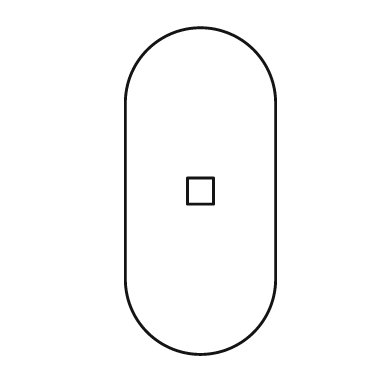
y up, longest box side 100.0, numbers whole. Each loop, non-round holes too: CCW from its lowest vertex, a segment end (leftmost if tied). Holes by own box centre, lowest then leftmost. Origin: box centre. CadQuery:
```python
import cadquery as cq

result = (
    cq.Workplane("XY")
    .moveTo(-23.0, -27.0)
    .threePointArc((0.0, -50.0), (23.0, -27.0))
    .lineTo(23.0, 27.0)
    .threePointArc((0.0, 50.0), (-23.0, 27.0))
    .close()
    .moveTo(-4.0, -4.0)
    .lineTo(4.0, -4.0)
    .lineTo(4.0, 4.0)
    .lineTo(-4.0, 4.0)
    .close()
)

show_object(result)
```